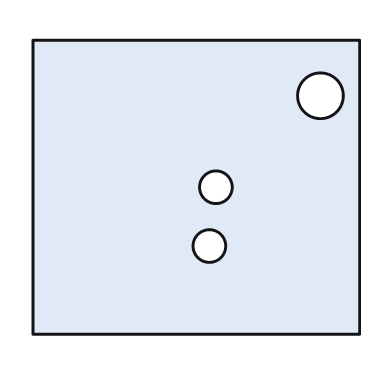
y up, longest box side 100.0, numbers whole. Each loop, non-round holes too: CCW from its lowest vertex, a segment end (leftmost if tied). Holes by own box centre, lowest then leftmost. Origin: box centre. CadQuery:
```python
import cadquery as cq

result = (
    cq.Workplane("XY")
    .moveTo(-50.0, -45.0)
    .lineTo(50.0, -45.0)
    .lineTo(50.0, 45.0)
    .lineTo(-50.0, 45.0)
    .close()
    .moveTo(4.0, -18.0)
    .circle(5.0)
    .moveTo(6.0, 0.0)
    .circle(5.0)
    .moveTo(38.0, 28.0)
    .circle(7.0)
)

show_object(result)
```